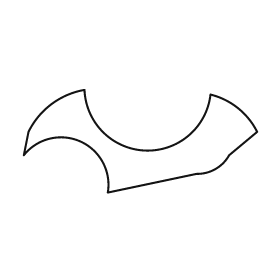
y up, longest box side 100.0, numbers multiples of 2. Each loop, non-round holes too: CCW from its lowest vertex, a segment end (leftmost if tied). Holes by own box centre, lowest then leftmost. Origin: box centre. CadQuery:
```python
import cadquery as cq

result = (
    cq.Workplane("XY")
    .moveTo(-14.0, -22.0)
    .lineTo(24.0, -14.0)
    .threePointArc((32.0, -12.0), (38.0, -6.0))
    .lineTo(50.0, 4.0)
    .threePointArc((42.0, 14.0), (30.0, 20.0))
    .threePointArc((2.0, -4.0), (-24.0, 22.0))
    .threePointArc((-38.0, 16.0), (-48.0, 4.0))
    .lineTo(-50.0, -6.0)
    .threePointArc((-26.0, 0.0), (-14.0, -22.0))
    .close()
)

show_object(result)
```